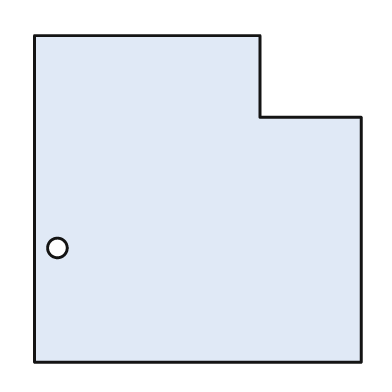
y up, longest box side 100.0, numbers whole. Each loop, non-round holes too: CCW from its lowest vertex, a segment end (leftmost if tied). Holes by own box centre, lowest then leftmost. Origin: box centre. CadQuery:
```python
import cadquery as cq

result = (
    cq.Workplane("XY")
    .moveTo(-50.0, -50.0)
    .lineTo(50.0, -50.0)
    .lineTo(50.0, 25.0)
    .lineTo(19.0, 25.0)
    .lineTo(19.0, 50.0)
    .lineTo(-50.0, 50.0)
    .close()
    .moveTo(-43.0, -15.0)
    .circle(3.0)
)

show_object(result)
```